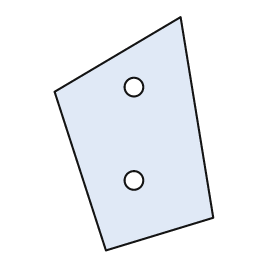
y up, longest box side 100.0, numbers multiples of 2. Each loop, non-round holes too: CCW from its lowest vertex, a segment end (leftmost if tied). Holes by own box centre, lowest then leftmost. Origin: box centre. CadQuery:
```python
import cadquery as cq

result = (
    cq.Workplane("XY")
    .moveTo(-12.0, -50.0)
    .lineTo(34.0, -36.0)
    .lineTo(20.0, 50.0)
    .lineTo(-34.0, 18.0)
    .close()
    .moveTo(0.0, -20.0)
    .circle(4.0)
    .moveTo(0.0, 20.0)
    .circle(4.0)
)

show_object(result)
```